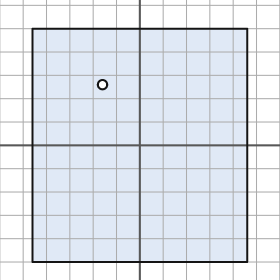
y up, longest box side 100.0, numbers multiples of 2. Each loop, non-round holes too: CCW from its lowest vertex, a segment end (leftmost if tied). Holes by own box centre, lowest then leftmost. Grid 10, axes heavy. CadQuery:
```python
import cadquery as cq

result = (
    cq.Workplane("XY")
    .moveTo(-46.0, -50.0)
    .lineTo(46.0, -50.0)
    .lineTo(46.0, 50.0)
    .lineTo(-46.0, 50.0)
    .close()
    .moveTo(-16.0, 26.0)
    .circle(2.0)
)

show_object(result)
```